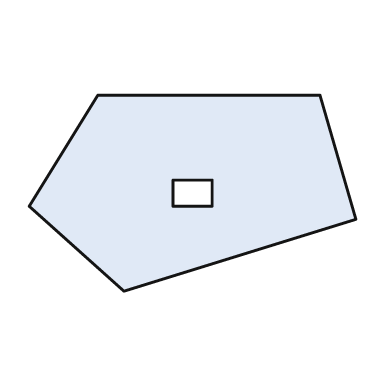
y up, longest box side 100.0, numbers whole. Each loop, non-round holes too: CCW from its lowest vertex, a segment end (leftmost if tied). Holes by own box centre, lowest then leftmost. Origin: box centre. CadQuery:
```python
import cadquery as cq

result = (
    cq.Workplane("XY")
    .moveTo(-21.0, -30.0)
    .lineTo(50.0, -8.0)
    .lineTo(39.0, 30.0)
    .lineTo(-29.0, 30.0)
    .lineTo(-50.0, -4.0)
    .close()
    .moveTo(-6.0, -4.0)
    .lineTo(6.0, -4.0)
    .lineTo(6.0, 4.0)
    .lineTo(-6.0, 4.0)
    .close()
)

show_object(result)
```